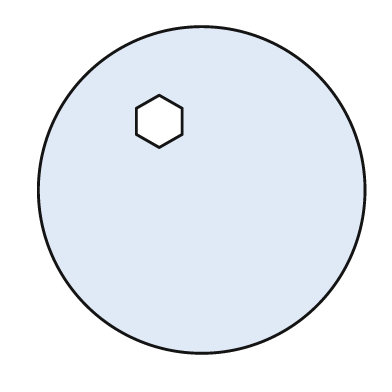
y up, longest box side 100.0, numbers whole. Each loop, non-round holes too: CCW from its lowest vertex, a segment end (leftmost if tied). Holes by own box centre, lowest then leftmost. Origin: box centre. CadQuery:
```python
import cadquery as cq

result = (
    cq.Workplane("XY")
    .moveTo(0.0, 0.0)
    .circle(50.0)
    .moveTo(-13.0, 13.0)
    .lineTo(-6.0, 17.0)
    .lineTo(-6.0, 25.0)
    .lineTo(-13.0, 29.0)
    .lineTo(-20.0, 25.0)
    .lineTo(-20.0, 17.0)
    .close()
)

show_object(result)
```